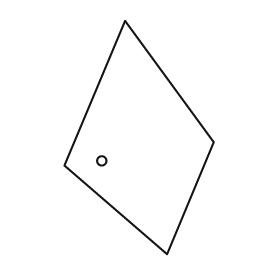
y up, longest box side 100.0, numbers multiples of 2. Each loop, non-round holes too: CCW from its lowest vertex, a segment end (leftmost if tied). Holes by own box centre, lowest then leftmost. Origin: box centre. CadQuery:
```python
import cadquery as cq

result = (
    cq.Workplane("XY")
    .moveTo(12.0, -50.0)
    .lineTo(32.0, -2.0)
    .lineTo(-6.0, 50.0)
    .lineTo(-32.0, -12.0)
    .close()
    .moveTo(-16.0, -10.0)
    .circle(2.0)
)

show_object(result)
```